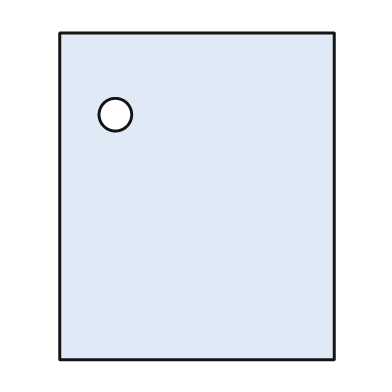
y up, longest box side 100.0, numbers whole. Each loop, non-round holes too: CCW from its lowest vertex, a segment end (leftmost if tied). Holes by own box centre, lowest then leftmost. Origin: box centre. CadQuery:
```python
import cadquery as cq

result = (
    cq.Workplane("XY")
    .moveTo(-42.0, -50.0)
    .lineTo(42.0, -50.0)
    .lineTo(42.0, 50.0)
    .lineTo(-42.0, 50.0)
    .close()
    .moveTo(-25.0, 25.0)
    .circle(5.0)
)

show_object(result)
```